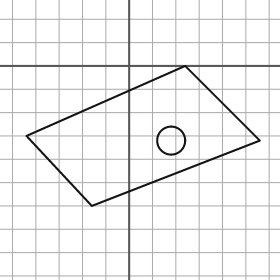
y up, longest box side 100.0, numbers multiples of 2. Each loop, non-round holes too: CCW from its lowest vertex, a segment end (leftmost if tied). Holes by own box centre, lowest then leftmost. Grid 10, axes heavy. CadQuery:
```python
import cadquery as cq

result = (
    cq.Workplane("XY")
    .moveTo(-16.0, -60.0)
    .lineTo(56.0, -32.0)
    .lineTo(24.0, 0.0)
    .lineTo(-44.0, -30.0)
    .close()
    .moveTo(18.0, -32.0)
    .circle(6.0)
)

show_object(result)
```